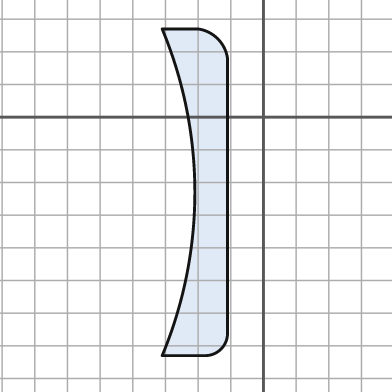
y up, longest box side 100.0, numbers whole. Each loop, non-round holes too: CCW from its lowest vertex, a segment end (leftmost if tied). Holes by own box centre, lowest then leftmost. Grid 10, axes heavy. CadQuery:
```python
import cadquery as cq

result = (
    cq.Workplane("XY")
    .moveTo(-31.0, -73.0)
    .lineTo(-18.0, -73.0)
    .threePointArc((-13.0, -71.0), (-11.0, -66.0))
    .lineTo(-11.0, 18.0)
    .threePointArc((-14.0, 24.0), (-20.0, 27.0))
    .lineTo(-31.0, 27.0)
    .threePointArc((-21.0, -23.0), (-31.0, -73.0))
    .close()
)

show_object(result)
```